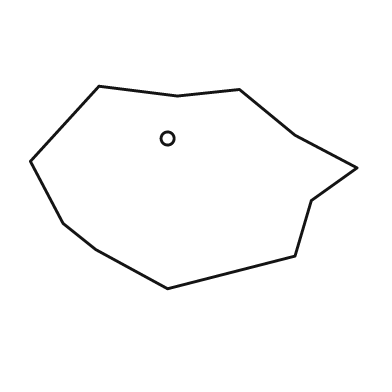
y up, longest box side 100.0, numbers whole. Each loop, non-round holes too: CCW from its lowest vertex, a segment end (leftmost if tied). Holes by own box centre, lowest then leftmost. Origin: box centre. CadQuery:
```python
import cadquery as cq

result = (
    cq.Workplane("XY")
    .moveTo(-8.0, -31.0)
    .lineTo(31.0, -21.0)
    .lineTo(36.0, -4.0)
    .lineTo(50.0, 6.0)
    .lineTo(31.0, 16.0)
    .lineTo(14.0, 30.0)
    .lineTo(-5.0, 28.0)
    .lineTo(-29.0, 31.0)
    .lineTo(-50.0, 8.0)
    .lineTo(-40.0, -11.0)
    .lineTo(-30.0, -19.0)
    .close()
    .moveTo(-8.0, 15.0)
    .circle(2.0)
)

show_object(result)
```